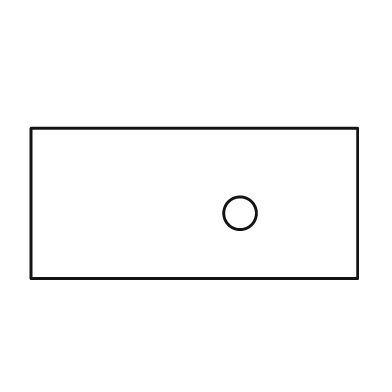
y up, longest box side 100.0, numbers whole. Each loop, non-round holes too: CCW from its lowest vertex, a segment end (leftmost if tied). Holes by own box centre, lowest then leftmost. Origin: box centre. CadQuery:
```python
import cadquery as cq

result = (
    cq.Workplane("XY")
    .moveTo(-50.0, -23.0)
    .lineTo(50.0, -23.0)
    .lineTo(50.0, 23.0)
    .lineTo(-50.0, 23.0)
    .close()
    .moveTo(14.0, -3.0)
    .circle(5.0)
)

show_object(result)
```